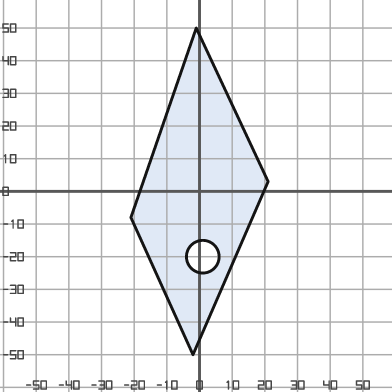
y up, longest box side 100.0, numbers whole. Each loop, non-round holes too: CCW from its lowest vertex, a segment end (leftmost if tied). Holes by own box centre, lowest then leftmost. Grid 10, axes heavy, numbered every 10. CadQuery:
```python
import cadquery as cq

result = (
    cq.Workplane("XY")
    .moveTo(-2.0, -50.0)
    .lineTo(21.0, 3.0)
    .lineTo(-1.0, 50.0)
    .lineTo(-21.0, -8.0)
    .close()
    .moveTo(1.0, -20.0)
    .circle(5.0)
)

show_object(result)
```